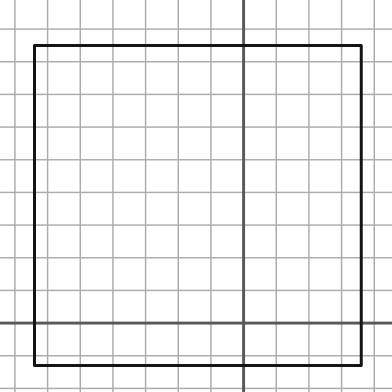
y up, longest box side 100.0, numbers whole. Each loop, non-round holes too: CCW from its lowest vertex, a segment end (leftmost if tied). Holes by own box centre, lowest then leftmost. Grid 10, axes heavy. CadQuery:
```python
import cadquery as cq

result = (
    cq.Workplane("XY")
    .moveTo(-64.0, -13.0)
    .lineTo(36.0, -13.0)
    .lineTo(36.0, 85.0)
    .lineTo(-64.0, 85.0)
    .close()
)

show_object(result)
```